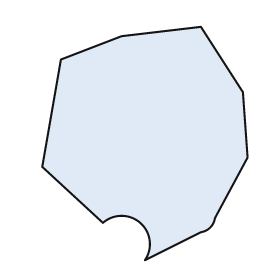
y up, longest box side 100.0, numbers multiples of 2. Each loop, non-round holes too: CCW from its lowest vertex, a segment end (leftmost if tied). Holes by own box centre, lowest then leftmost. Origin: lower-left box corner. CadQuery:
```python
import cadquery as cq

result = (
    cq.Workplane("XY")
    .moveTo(44.0, 0.0)
    .lineTo(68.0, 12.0)
    .threePointArc((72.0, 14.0), (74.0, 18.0))
    .lineTo(88.0, 44.0)
    .lineTo(86.0, 72.0)
    .lineTo(68.0, 100.0)
    .lineTo(34.0, 96.0)
    .lineTo(8.0, 86.0)
    .lineTo(0.0, 40.0)
    .lineTo(26.0, 16.0)
    .threePointArc((42.0, 16.0), (44.0, 0.0))
    .close()
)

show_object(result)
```